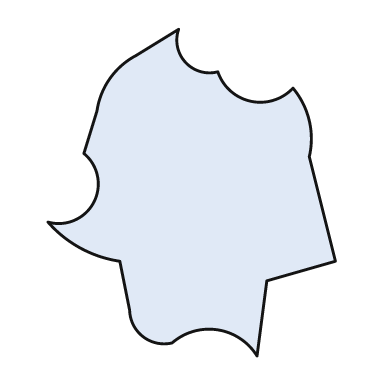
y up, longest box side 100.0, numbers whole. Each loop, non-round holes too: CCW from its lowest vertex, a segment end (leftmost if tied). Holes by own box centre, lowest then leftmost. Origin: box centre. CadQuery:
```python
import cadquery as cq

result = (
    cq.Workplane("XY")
    .moveTo(20.0, -50.0)
    .lineTo(23.0, -27.0)
    .lineTo(44.0, -21.0)
    .lineTo(36.0, 11.0)
    .threePointArc((36.0, 22.0), (31.0, 32.0))
    .threePointArc((18.0, 28.0), (8.0, 37.0))
    .threePointArc((-2.0, 40.0), (-4.0, 50.0))
    .lineTo(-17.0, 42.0)
    .threePointArc((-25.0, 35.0), (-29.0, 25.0))
    .lineTo(-33.0, 12.0)
    .threePointArc((-30.0, -3.0), (-44.0, -9.0))
    .threePointArc((-34.0, -17.0), (-22.0, -21.0))
    .lineTo(-19.0, -36.0)
    .threePointArc((-15.0, -44.0), (-6.0, -46.0))
    .threePointArc((8.0, -42.0), (20.0, -50.0))
    .close()
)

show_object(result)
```